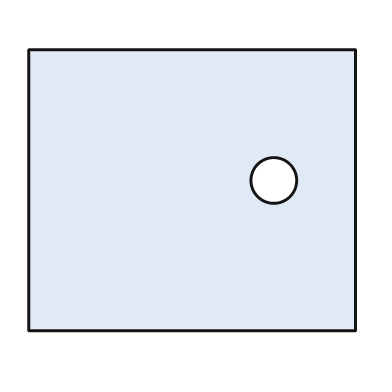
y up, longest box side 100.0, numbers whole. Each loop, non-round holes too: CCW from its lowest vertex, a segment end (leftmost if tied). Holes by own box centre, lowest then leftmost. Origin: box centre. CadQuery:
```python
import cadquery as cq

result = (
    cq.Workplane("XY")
    .moveTo(-50.0, -43.0)
    .lineTo(50.0, -43.0)
    .lineTo(50.0, 43.0)
    .lineTo(-50.0, 43.0)
    .close()
    .moveTo(25.0, 3.0)
    .circle(7.0)
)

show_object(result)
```